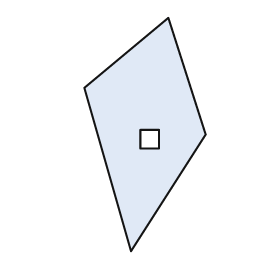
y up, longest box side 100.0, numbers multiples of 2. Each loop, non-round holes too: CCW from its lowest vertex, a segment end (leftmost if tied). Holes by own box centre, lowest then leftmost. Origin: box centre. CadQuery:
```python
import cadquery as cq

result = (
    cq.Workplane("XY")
    .moveTo(-6.0, -50.0)
    .lineTo(26.0, 0.0)
    .lineTo(10.0, 50.0)
    .lineTo(-26.0, 20.0)
    .close()
    .moveTo(-2.0, -6.0)
    .lineTo(6.0, -6.0)
    .lineTo(6.0, 2.0)
    .lineTo(-2.0, 2.0)
    .close()
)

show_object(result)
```